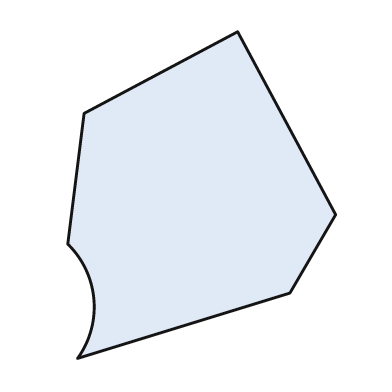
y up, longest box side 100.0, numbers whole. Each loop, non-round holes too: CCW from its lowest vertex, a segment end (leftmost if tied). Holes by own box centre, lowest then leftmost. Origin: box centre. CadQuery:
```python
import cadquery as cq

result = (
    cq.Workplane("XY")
    .moveTo(-38.0, -50.0)
    .lineTo(27.0, -30.0)
    .lineTo(41.0, -6.0)
    .lineTo(11.0, 50.0)
    .lineTo(-36.0, 25.0)
    .lineTo(-41.0, -15.0)
    .threePointArc((-33.0, -32.0), (-38.0, -50.0))
    .close()
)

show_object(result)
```